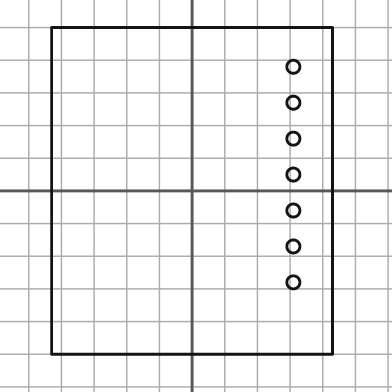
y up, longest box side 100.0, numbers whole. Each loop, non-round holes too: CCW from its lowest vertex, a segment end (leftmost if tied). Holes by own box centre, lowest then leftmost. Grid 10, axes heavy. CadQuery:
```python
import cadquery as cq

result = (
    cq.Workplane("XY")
    .moveTo(-43.0, -50.0)
    .lineTo(43.0, -50.0)
    .lineTo(43.0, 50.0)
    .lineTo(-43.0, 50.0)
    .close()
    .moveTo(31.0, -28.0)
    .circle(2.0)
    .moveTo(31.0, -17.0)
    .circle(2.0)
    .moveTo(31.0, -6.0)
    .circle(2.0)
    .moveTo(31.0, 5.0)
    .circle(2.0)
    .moveTo(31.0, 16.0)
    .circle(2.0)
    .moveTo(31.0, 27.0)
    .circle(2.0)
    .moveTo(31.0, 38.0)
    .circle(2.0)
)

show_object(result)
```